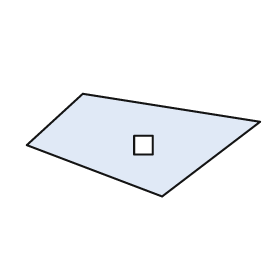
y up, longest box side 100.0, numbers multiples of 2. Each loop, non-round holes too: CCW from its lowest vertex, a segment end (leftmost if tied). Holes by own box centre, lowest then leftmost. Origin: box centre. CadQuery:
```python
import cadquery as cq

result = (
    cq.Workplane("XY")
    .moveTo(8.0, -22.0)
    .lineTo(50.0, 10.0)
    .lineTo(-26.0, 22.0)
    .lineTo(-50.0, 0.0)
    .close()
    .moveTo(-4.0, -4.0)
    .lineTo(4.0, -4.0)
    .lineTo(4.0, 4.0)
    .lineTo(-4.0, 4.0)
    .close()
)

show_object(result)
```